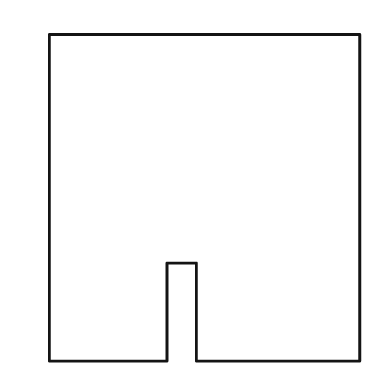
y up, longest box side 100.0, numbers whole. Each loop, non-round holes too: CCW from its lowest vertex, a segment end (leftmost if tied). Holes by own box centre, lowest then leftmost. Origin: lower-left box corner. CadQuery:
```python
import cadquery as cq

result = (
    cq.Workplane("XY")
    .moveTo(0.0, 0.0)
    .lineTo(36.0, 0.0)
    .lineTo(36.0, 30.0)
    .lineTo(45.0, 30.0)
    .lineTo(45.0, 0.0)
    .lineTo(95.0, 0.0)
    .lineTo(95.0, 100.0)
    .lineTo(0.0, 100.0)
    .close()
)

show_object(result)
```